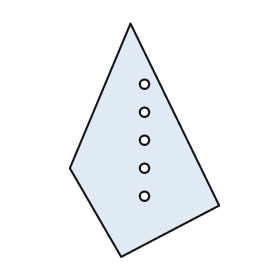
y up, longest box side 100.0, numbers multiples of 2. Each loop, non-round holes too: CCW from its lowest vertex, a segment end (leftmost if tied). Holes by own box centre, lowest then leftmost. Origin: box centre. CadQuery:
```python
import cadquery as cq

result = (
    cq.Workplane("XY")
    .moveTo(-10.0, -50.0)
    .lineTo(32.0, -28.0)
    .lineTo(-6.0, 50.0)
    .lineTo(-32.0, -12.0)
    .close()
    .moveTo(0.0, -24.0)
    .circle(2.0)
    .moveTo(0.0, -12.0)
    .circle(2.0)
    .moveTo(0.0, 0.0)
    .circle(2.0)
    .moveTo(0.0, 12.0)
    .circle(2.0)
    .moveTo(0.0, 24.0)
    .circle(2.0)
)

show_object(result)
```